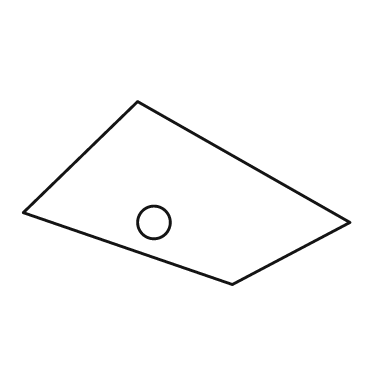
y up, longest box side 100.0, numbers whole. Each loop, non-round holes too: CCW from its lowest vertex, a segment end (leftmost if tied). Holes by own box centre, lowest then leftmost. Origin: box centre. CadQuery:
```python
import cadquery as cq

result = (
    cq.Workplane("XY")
    .moveTo(14.0, -28.0)
    .lineTo(50.0, -9.0)
    .lineTo(-15.0, 28.0)
    .lineTo(-50.0, -6.0)
    .close()
    .moveTo(-10.0, -9.0)
    .circle(5.0)
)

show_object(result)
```